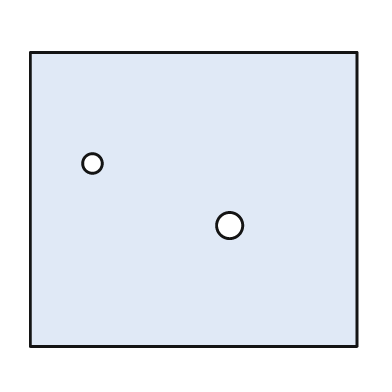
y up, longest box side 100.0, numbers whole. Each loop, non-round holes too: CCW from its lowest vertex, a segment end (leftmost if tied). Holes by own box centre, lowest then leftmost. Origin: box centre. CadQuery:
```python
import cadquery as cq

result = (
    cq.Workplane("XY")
    .moveTo(-50.0, -45.0)
    .lineTo(50.0, -45.0)
    .lineTo(50.0, 45.0)
    .lineTo(-50.0, 45.0)
    .close()
    .moveTo(11.0, -8.0)
    .circle(4.0)
    .moveTo(-31.0, 11.0)
    .circle(3.0)
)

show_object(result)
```